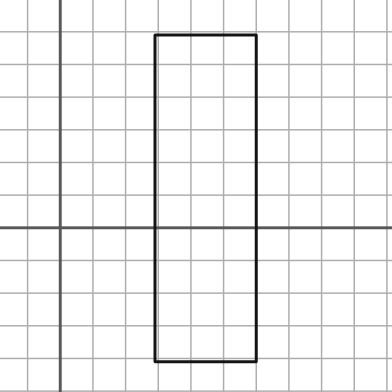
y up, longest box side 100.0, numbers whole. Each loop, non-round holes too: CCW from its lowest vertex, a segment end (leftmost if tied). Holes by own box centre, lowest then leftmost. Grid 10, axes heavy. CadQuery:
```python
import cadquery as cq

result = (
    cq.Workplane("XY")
    .moveTo(29.0, -41.0)
    .lineTo(60.0, -41.0)
    .lineTo(60.0, 59.0)
    .lineTo(29.0, 59.0)
    .close()
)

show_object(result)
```